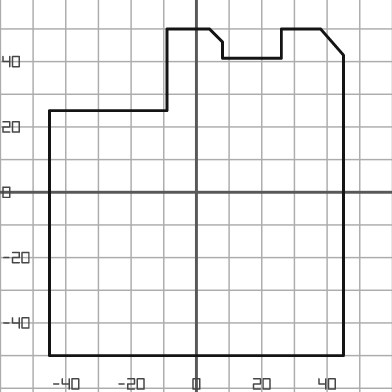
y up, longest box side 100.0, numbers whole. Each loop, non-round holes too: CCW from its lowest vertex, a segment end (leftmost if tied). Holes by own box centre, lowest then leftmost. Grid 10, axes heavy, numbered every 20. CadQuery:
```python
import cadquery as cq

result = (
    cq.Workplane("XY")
    .moveTo(-45.0, -50.0)
    .lineTo(45.0, -50.0)
    .lineTo(45.0, 42.0)
    .lineTo(38.0, 50.0)
    .lineTo(26.0, 50.0)
    .lineTo(26.0, 41.0)
    .lineTo(8.0, 41.0)
    .lineTo(8.0, 46.0)
    .lineTo(4.0, 50.0)
    .lineTo(-9.0, 50.0)
    .lineTo(-9.0, 25.0)
    .lineTo(-45.0, 25.0)
    .close()
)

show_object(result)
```